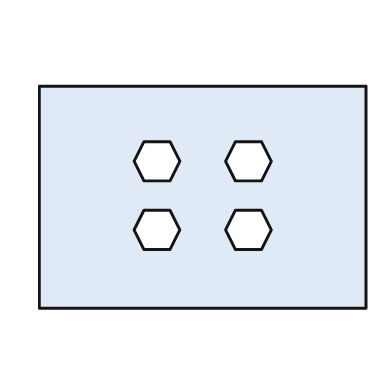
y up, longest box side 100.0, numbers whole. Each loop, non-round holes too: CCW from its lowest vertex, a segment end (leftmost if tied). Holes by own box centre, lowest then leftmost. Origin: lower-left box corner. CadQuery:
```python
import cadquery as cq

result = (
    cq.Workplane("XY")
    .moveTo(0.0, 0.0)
    .lineTo(100.0, 0.0)
    .lineTo(100.0, 68.0)
    .lineTo(0.0, 68.0)
    .close()
    .moveTo(32.0, 18.0)
    .lineTo(40.0, 18.0)
    .lineTo(43.0, 24.0)
    .lineTo(40.0, 30.0)
    .lineTo(32.0, 30.0)
    .lineTo(29.0, 24.0)
    .close()
    .moveTo(60.0, 18.0)
    .lineTo(68.0, 18.0)
    .lineTo(71.0, 24.0)
    .lineTo(68.0, 30.0)
    .lineTo(60.0, 30.0)
    .lineTo(57.0, 24.0)
    .close()
    .moveTo(32.0, 39.0)
    .lineTo(40.0, 39.0)
    .lineTo(43.0, 45.0)
    .lineTo(40.0, 51.0)
    .lineTo(32.0, 51.0)
    .lineTo(29.0, 45.0)
    .close()
    .moveTo(60.0, 39.0)
    .lineTo(68.0, 39.0)
    .lineTo(71.0, 45.0)
    .lineTo(68.0, 51.0)
    .lineTo(60.0, 51.0)
    .lineTo(57.0, 45.0)
    .close()
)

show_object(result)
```